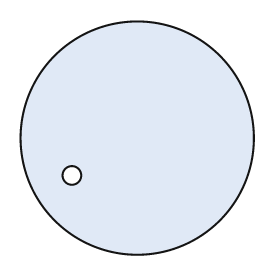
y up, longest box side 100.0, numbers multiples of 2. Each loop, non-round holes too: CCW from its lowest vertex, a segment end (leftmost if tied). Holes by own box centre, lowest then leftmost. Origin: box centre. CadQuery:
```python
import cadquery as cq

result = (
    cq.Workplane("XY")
    .moveTo(0.0, 0.0)
    .circle(50.0)
    .moveTo(-28.0, -16.0)
    .circle(4.0)
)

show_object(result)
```